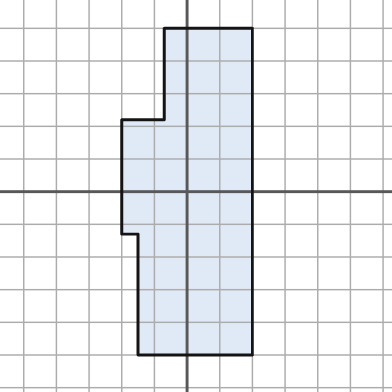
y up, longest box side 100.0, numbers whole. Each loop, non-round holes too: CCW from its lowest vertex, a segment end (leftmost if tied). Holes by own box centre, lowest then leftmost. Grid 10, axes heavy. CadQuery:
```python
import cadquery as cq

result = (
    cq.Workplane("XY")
    .moveTo(-15.0, -50.0)
    .lineTo(20.0, -50.0)
    .lineTo(20.0, 50.0)
    .lineTo(-7.0, 50.0)
    .lineTo(-7.0, 22.0)
    .lineTo(-20.0, 22.0)
    .lineTo(-20.0, -13.0)
    .lineTo(-15.0, -13.0)
    .close()
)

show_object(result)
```